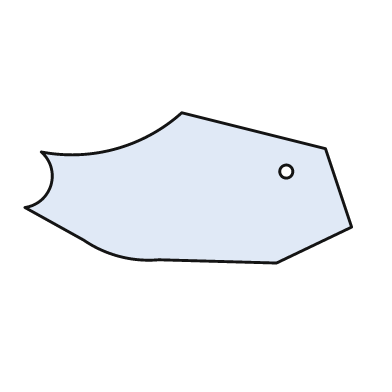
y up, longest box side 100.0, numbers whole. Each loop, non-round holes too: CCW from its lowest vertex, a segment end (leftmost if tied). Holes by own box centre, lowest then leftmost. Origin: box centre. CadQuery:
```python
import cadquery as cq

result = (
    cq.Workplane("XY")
    .moveTo(27.0, -23.0)
    .lineTo(50.0, -12.0)
    .lineTo(42.0, 12.0)
    .lineTo(-2.0, 23.0)
    .threePointArc((-22.0, 12.0), (-45.0, 11.0))
    .threePointArc((-42.0, 1.0), (-50.0, -6.0))
    .lineTo(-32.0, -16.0)
    .threePointArc((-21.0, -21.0), (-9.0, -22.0))
    .close()
    .moveTo(30.0, 5.0)
    .circle(2.0)
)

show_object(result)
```